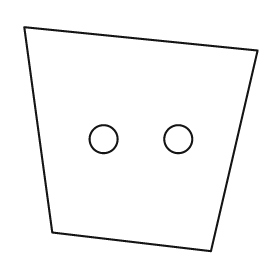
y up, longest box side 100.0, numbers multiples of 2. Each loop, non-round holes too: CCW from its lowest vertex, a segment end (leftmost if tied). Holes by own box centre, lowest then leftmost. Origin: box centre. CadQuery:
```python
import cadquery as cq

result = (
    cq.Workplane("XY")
    .moveTo(30.0, -48.0)
    .lineTo(50.0, 38.0)
    .lineTo(-50.0, 48.0)
    .lineTo(-38.0, -40.0)
    .close()
    .moveTo(-16.0, 0.0)
    .circle(6.0)
    .moveTo(16.0, 0.0)
    .circle(6.0)
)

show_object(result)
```